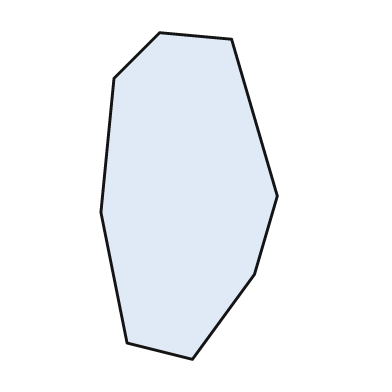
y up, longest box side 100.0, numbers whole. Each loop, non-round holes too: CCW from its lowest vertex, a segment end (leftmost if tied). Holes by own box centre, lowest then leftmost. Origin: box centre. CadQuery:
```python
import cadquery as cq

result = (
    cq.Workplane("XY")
    .moveTo(1.0, -50.0)
    .lineTo(20.0, -24.0)
    .lineTo(27.0, 0.0)
    .lineTo(13.0, 48.0)
    .lineTo(-9.0, 50.0)
    .lineTo(-23.0, 36.0)
    .lineTo(-27.0, -5.0)
    .lineTo(-19.0, -45.0)
    .close()
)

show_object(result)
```